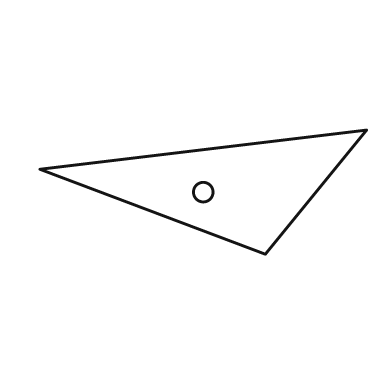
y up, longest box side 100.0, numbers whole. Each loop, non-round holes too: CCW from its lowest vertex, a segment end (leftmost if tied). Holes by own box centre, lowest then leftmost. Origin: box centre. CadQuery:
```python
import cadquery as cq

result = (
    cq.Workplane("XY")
    .moveTo(19.0, -19.0)
    .lineTo(50.0, 19.0)
    .lineTo(-50.0, 7.0)
    .close()
    .moveTo(0.0, 0.0)
    .circle(3.0)
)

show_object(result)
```